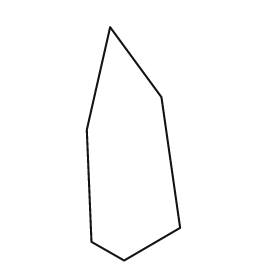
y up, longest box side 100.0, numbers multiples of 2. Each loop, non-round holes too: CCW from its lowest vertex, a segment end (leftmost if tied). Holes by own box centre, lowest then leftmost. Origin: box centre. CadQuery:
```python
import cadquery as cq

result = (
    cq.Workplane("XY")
    .moveTo(-4.0, -50.0)
    .lineTo(20.0, -36.0)
    .lineTo(12.0, 20.0)
    .lineTo(-10.0, 50.0)
    .lineTo(-20.0, 6.0)
    .lineTo(-18.0, -42.0)
    .close()
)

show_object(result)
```